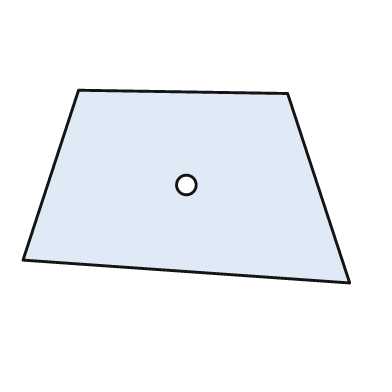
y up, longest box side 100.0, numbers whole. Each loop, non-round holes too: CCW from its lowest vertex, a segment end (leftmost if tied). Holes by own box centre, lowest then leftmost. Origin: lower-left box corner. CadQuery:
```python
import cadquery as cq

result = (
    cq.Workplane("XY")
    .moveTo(100.0, 0.0)
    .lineTo(81.0, 58.0)
    .lineTo(17.0, 59.0)
    .lineTo(0.0, 7.0)
    .close()
    .moveTo(50.0, 30.0)
    .circle(3.0)
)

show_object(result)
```